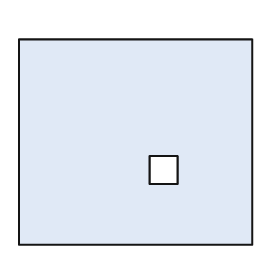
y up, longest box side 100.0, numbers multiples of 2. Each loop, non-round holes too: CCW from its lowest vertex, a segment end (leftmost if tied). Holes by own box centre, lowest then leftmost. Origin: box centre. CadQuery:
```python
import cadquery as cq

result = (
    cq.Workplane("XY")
    .moveTo(-50.0, -44.0)
    .lineTo(50.0, -44.0)
    .lineTo(50.0, 44.0)
    .lineTo(-50.0, 44.0)
    .close()
    .moveTo(6.0, -18.0)
    .lineTo(18.0, -18.0)
    .lineTo(18.0, -6.0)
    .lineTo(6.0, -6.0)
    .close()
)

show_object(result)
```